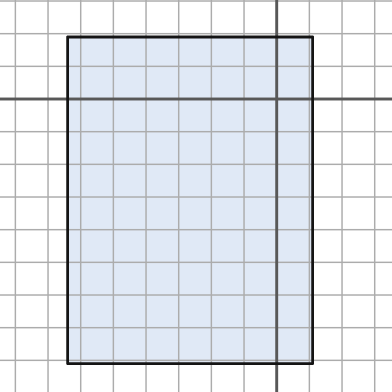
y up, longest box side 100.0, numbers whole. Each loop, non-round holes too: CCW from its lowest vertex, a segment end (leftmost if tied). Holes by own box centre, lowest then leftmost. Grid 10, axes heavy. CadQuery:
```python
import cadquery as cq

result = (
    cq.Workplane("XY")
    .moveTo(-64.0, -81.0)
    .lineTo(11.0, -81.0)
    .lineTo(11.0, 19.0)
    .lineTo(-64.0, 19.0)
    .close()
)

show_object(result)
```